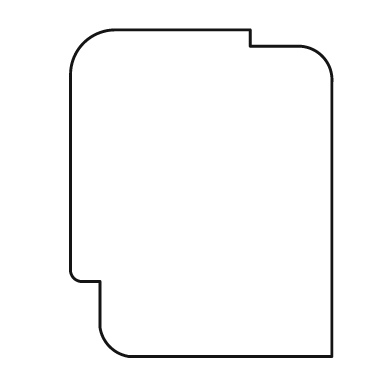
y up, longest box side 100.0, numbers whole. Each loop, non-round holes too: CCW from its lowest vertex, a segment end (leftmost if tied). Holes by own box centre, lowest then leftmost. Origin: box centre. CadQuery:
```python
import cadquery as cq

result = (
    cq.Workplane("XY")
    .moveTo(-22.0, -50.0)
    .lineTo(40.0, -50.0)
    .lineTo(40.0, 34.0)
    .threePointArc((37.0, 42.0), (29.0, 45.0))
    .lineTo(15.0, 45.0)
    .lineTo(15.0, 50.0)
    .lineTo(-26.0, 50.0)
    .threePointArc((-36.0, 46.0), (-40.0, 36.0))
    .lineTo(-40.0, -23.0)
    .threePointArc((-39.0, -26.0), (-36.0, -27.0))
    .lineTo(-31.0, -27.0)
    .lineTo(-31.0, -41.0)
    .threePointArc((-28.0, -47.0), (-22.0, -50.0))
    .close()
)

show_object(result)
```